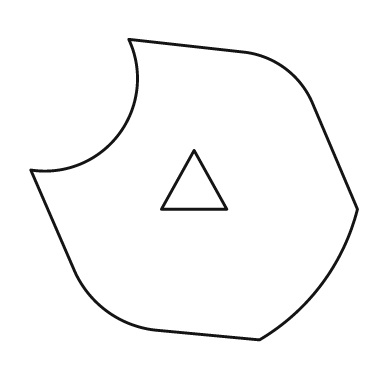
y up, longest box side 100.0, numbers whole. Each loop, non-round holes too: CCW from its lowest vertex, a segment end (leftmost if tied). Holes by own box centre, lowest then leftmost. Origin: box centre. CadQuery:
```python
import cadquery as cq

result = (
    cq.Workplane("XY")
    .moveTo(20.0, -46.0)
    .threePointArc((39.0, -29.0), (50.0, -6.0))
    .lineTo(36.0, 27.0)
    .threePointArc((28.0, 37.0), (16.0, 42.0))
    .lineTo(-20.0, 46.0)
    .threePointArc((-23.0, 17.0), (-50.0, 6.0))
    .lineTo(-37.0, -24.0)
    .threePointArc((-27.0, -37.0), (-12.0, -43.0))
    .close()
    .moveTo(-10.0, -6.0)
    .lineTo(10.0, -6.0)
    .lineTo(0.0, 12.0)
    .close()
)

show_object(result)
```